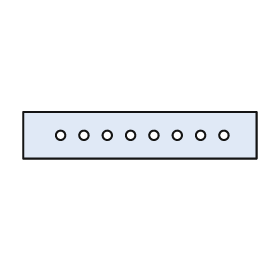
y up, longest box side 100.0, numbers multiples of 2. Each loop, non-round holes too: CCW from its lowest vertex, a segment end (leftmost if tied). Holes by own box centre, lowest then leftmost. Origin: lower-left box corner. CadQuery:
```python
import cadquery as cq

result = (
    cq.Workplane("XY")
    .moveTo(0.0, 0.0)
    .lineTo(100.0, 0.0)
    .lineTo(100.0, 20.0)
    .lineTo(0.0, 20.0)
    .close()
    .moveTo(16.0, 10.0)
    .circle(2.0)
    .moveTo(26.0, 10.0)
    .circle(2.0)
    .moveTo(36.0, 10.0)
    .circle(2.0)
    .moveTo(46.0, 10.0)
    .circle(2.0)
    .moveTo(56.0, 10.0)
    .circle(2.0)
    .moveTo(66.0, 10.0)
    .circle(2.0)
    .moveTo(76.0, 10.0)
    .circle(2.0)
    .moveTo(86.0, 10.0)
    .circle(2.0)
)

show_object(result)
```